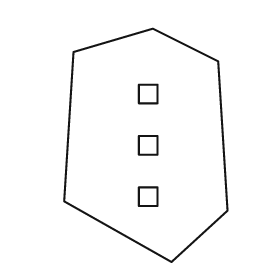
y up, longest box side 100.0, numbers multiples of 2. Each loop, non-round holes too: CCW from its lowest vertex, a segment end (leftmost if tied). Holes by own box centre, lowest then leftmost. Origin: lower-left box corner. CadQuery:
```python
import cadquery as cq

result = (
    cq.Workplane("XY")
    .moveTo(46.0, 0.0)
    .lineTo(70.0, 22.0)
    .lineTo(66.0, 86.0)
    .lineTo(38.0, 100.0)
    .lineTo(4.0, 90.0)
    .lineTo(0.0, 26.0)
    .close()
    .moveTo(32.0, 24.0)
    .lineTo(40.0, 24.0)
    .lineTo(40.0, 32.0)
    .lineTo(32.0, 32.0)
    .close()
    .moveTo(32.0, 46.0)
    .lineTo(40.0, 46.0)
    .lineTo(40.0, 54.0)
    .lineTo(32.0, 54.0)
    .close()
    .moveTo(32.0, 68.0)
    .lineTo(40.0, 68.0)
    .lineTo(40.0, 76.0)
    .lineTo(32.0, 76.0)
    .close()
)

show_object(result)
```